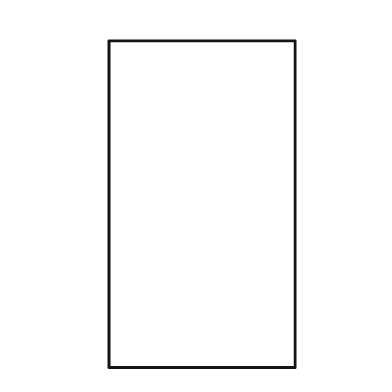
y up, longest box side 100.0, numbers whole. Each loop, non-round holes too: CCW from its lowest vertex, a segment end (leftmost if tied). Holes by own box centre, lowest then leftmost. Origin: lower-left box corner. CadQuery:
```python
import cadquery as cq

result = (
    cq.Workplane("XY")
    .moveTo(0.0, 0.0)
    .lineTo(57.0, 0.0)
    .lineTo(57.0, 100.0)
    .lineTo(0.0, 100.0)
    .close()
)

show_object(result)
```